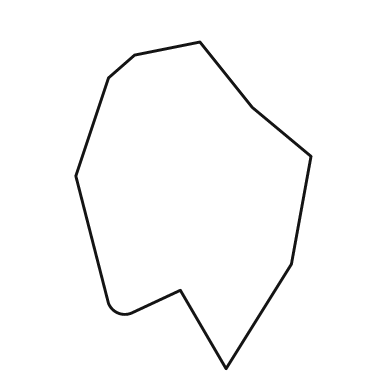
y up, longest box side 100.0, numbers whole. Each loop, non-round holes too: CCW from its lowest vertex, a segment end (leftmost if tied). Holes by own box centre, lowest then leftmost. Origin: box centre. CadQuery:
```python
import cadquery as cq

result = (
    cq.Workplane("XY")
    .moveTo(10.0, -50.0)
    .lineTo(30.0, -18.0)
    .lineTo(36.0, 15.0)
    .lineTo(18.0, 30.0)
    .lineTo(2.0, 50.0)
    .lineTo(-18.0, 46.0)
    .lineTo(-26.0, 39.0)
    .lineTo(-36.0, 9.0)
    .lineTo(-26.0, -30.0)
    .threePointArc((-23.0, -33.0), (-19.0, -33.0))
    .lineTo(-4.0, -26.0)
    .close()
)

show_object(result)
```